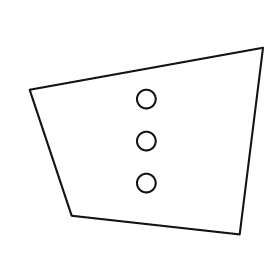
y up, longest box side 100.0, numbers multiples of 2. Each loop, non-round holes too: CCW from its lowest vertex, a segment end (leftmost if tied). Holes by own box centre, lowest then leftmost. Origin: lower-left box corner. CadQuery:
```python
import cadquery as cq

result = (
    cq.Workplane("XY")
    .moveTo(90.0, 0.0)
    .lineTo(100.0, 80.0)
    .lineTo(0.0, 62.0)
    .lineTo(18.0, 8.0)
    .close()
    .moveTo(50.0, 22.0)
    .circle(4.0)
    .moveTo(50.0, 40.0)
    .circle(4.0)
    .moveTo(50.0, 58.0)
    .circle(4.0)
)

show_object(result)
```